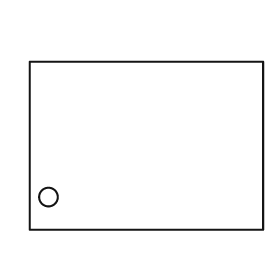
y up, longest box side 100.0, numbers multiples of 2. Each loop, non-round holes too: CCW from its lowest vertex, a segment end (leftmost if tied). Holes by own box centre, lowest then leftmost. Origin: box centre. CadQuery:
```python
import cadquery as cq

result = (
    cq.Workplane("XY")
    .moveTo(-50.0, -36.0)
    .lineTo(50.0, -36.0)
    .lineTo(50.0, 36.0)
    .lineTo(-50.0, 36.0)
    .close()
    .moveTo(-42.0, -22.0)
    .circle(4.0)
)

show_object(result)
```